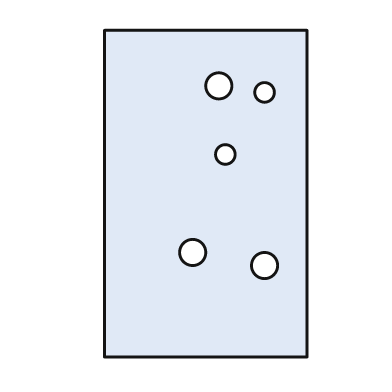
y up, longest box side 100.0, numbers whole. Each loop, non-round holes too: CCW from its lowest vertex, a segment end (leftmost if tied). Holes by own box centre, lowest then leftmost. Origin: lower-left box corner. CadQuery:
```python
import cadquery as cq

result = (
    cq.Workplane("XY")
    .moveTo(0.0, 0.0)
    .lineTo(62.0, 0.0)
    .lineTo(62.0, 100.0)
    .lineTo(0.0, 100.0)
    .close()
    .moveTo(49.0, 28.0)
    .circle(4.0)
    .moveTo(27.0, 32.0)
    .circle(4.0)
    .moveTo(37.0, 62.0)
    .circle(3.0)
    .moveTo(49.0, 81.0)
    .circle(3.0)
    .moveTo(35.0, 83.0)
    .circle(4.0)
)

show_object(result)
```